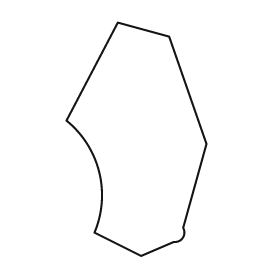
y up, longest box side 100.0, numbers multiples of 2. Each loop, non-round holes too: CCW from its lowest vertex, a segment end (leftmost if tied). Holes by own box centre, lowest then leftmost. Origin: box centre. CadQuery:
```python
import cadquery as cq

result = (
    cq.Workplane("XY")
    .moveTo(2.0, -50.0)
    .lineTo(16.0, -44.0)
    .threePointArc((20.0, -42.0), (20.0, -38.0))
    .lineTo(30.0, -2.0)
    .lineTo(14.0, 44.0)
    .lineTo(-8.0, 50.0)
    .lineTo(-30.0, 8.0)
    .threePointArc((-16.0, -14.0), (-18.0, -40.0))
    .close()
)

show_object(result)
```